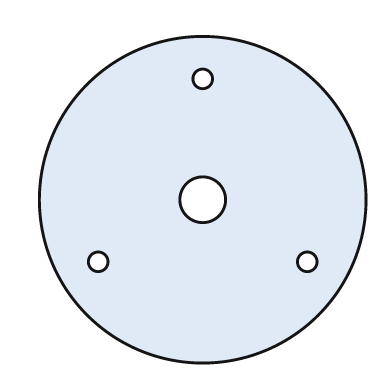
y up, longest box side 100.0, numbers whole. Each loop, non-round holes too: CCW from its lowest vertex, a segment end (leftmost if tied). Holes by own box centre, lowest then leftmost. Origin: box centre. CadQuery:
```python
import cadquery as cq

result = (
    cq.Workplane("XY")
    .moveTo(0.0, 0.0)
    .circle(50.0)
    .moveTo(-32.0, -19.0)
    .circle(3.0)
    .moveTo(32.0, -19.0)
    .circle(3.0)
    .moveTo(0.0, 0.0)
    .circle(7.0)
    .moveTo(0.0, 37.0)
    .circle(3.0)
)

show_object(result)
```